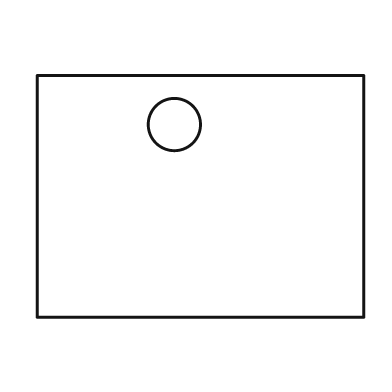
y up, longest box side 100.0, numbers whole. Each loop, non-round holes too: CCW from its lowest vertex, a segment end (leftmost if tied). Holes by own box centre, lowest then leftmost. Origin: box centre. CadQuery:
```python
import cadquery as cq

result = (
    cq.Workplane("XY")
    .moveTo(-50.0, -37.0)
    .lineTo(50.0, -37.0)
    .lineTo(50.0, 37.0)
    .lineTo(-50.0, 37.0)
    .close()
    .moveTo(-8.0, 22.0)
    .circle(8.0)
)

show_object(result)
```